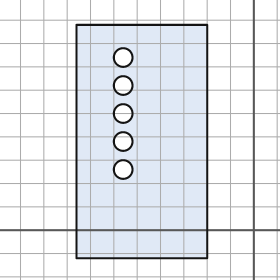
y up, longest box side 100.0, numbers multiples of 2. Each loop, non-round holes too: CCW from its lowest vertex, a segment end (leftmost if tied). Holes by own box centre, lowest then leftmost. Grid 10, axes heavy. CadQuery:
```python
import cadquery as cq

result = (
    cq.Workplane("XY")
    .moveTo(-76.0, -12.0)
    .lineTo(-20.0, -12.0)
    .lineTo(-20.0, 88.0)
    .lineTo(-76.0, 88.0)
    .close()
    .moveTo(-56.0, 26.0)
    .circle(4.0)
    .moveTo(-56.0, 38.0)
    .circle(4.0)
    .moveTo(-56.0, 50.0)
    .circle(4.0)
    .moveTo(-56.0, 62.0)
    .circle(4.0)
    .moveTo(-56.0, 74.0)
    .circle(4.0)
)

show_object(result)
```